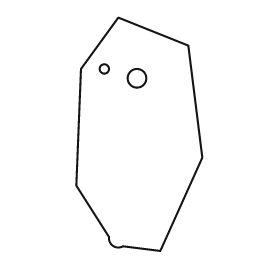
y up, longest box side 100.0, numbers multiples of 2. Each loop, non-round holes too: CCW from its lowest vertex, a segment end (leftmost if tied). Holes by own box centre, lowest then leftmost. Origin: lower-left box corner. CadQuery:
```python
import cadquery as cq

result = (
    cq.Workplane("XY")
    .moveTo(36.0, 0.0)
    .lineTo(54.0, 40.0)
    .lineTo(48.0, 88.0)
    .lineTo(18.0, 100.0)
    .lineTo(2.0, 78.0)
    .lineTo(0.0, 28.0)
    .lineTo(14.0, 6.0)
    .threePointArc((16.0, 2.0), (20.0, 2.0))
    .close()
    .moveTo(26.0, 74.0)
    .circle(4.0)
    .moveTo(12.0, 78.0)
    .circle(2.0)
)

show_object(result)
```